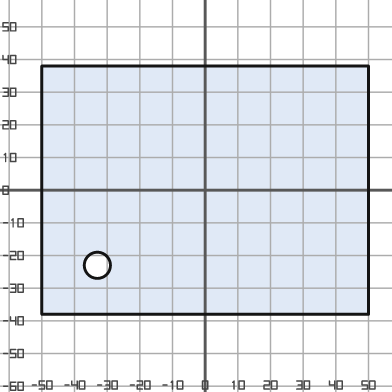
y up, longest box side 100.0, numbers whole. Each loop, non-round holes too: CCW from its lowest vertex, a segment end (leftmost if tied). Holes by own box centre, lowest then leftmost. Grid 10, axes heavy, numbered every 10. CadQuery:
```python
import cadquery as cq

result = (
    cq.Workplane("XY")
    .moveTo(-50.0, -38.0)
    .lineTo(50.0, -38.0)
    .lineTo(50.0, 38.0)
    .lineTo(-50.0, 38.0)
    .close()
    .moveTo(-33.0, -23.0)
    .circle(4.0)
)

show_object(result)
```